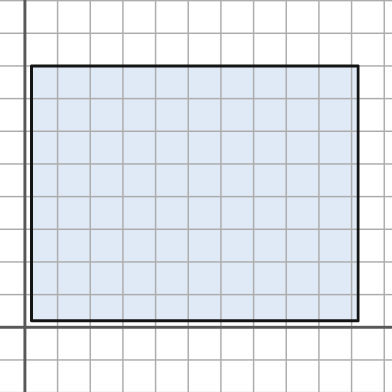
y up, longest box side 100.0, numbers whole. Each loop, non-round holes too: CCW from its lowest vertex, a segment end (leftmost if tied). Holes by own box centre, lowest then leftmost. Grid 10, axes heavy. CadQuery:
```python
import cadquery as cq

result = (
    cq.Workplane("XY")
    .moveTo(2.0, 2.0)
    .lineTo(102.0, 2.0)
    .lineTo(102.0, 80.0)
    .lineTo(2.0, 80.0)
    .close()
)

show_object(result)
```